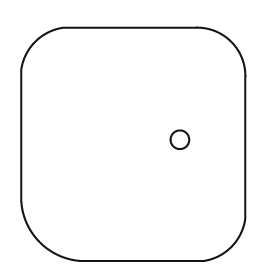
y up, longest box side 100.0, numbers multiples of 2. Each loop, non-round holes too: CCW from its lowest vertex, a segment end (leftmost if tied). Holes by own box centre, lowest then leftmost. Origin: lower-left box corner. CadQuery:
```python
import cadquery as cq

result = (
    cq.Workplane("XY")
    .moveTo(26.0, 0.0)
    .lineTo(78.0, 0.0)
    .threePointArc((90.0, 6.0), (96.0, 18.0))
    .lineTo(96.0, 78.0)
    .threePointArc((90.0, 94.0), (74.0, 100.0))
    .lineTo(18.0, 100.0)
    .threePointArc((6.0, 94.0), (0.0, 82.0))
    .lineTo(0.0, 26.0)
    .threePointArc((8.0, 8.0), (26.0, 0.0))
    .close()
    .moveTo(68.0, 52.0)
    .circle(4.0)
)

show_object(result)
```